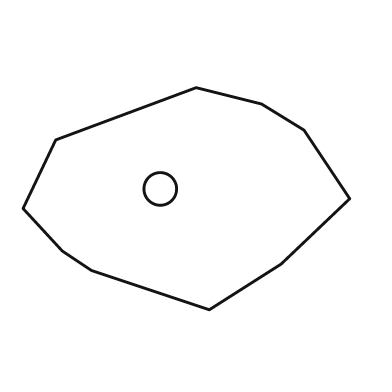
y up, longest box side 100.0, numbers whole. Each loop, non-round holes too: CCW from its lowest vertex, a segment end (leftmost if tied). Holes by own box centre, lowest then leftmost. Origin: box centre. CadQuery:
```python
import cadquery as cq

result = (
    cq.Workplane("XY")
    .moveTo(7.0, -34.0)
    .lineTo(29.0, -20.0)
    .lineTo(50.0, 0.0)
    .lineTo(36.0, 21.0)
    .lineTo(23.0, 29.0)
    .lineTo(3.0, 34.0)
    .lineTo(-40.0, 18.0)
    .lineTo(-50.0, -3.0)
    .lineTo(-38.0, -16.0)
    .lineTo(-29.0, -22.0)
    .close()
    .moveTo(-8.0, 3.0)
    .circle(5.0)
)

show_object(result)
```